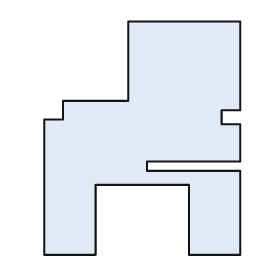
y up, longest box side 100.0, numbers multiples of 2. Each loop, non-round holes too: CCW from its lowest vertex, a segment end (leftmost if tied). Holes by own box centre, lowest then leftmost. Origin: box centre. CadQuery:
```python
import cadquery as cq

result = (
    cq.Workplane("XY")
    .moveTo(-42.0, -50.0)
    .lineTo(-20.0, -50.0)
    .lineTo(-20.0, -20.0)
    .lineTo(20.0, -20.0)
    .lineTo(20.0, -50.0)
    .lineTo(42.0, -50.0)
    .lineTo(42.0, -14.0)
    .lineTo(2.0, -14.0)
    .lineTo(2.0, -10.0)
    .lineTo(42.0, -10.0)
    .lineTo(42.0, 6.0)
    .lineTo(34.0, 6.0)
    .lineTo(34.0, 12.0)
    .lineTo(42.0, 12.0)
    .lineTo(42.0, 50.0)
    .lineTo(-6.0, 50.0)
    .lineTo(-6.0, 16.0)
    .lineTo(-34.0, 16.0)
    .lineTo(-34.0, 8.0)
    .lineTo(-42.0, 8.0)
    .close()
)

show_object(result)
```